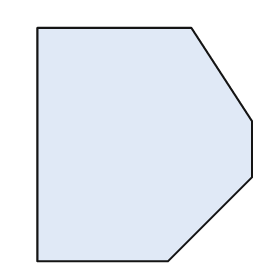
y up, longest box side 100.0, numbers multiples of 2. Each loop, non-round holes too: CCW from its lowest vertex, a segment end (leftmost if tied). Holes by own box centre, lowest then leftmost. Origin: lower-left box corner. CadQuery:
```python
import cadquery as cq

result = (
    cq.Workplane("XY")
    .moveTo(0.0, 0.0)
    .lineTo(56.0, 0.0)
    .lineTo(92.0, 36.0)
    .lineTo(92.0, 60.0)
    .lineTo(66.0, 100.0)
    .lineTo(0.0, 100.0)
    .close()
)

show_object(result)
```